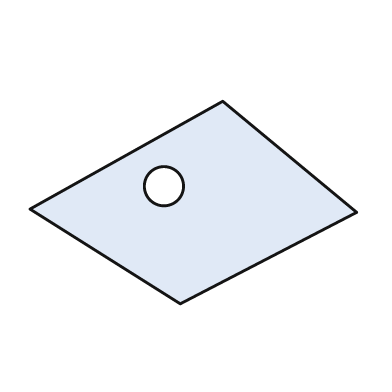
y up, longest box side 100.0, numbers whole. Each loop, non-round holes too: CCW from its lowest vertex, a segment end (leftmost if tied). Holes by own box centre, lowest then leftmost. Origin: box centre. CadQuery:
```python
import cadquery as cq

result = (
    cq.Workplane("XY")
    .moveTo(-4.0, -31.0)
    .lineTo(50.0, -3.0)
    .lineTo(9.0, 31.0)
    .lineTo(-50.0, -2.0)
    .close()
    .moveTo(-9.0, 5.0)
    .circle(6.0)
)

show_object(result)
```